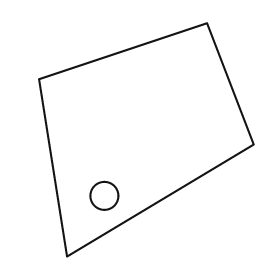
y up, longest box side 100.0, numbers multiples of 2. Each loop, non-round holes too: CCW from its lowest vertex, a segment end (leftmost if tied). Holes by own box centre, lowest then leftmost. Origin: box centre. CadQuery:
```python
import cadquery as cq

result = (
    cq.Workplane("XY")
    .moveTo(-34.0, -50.0)
    .lineTo(46.0, -2.0)
    .lineTo(26.0, 50.0)
    .lineTo(-46.0, 26.0)
    .close()
    .moveTo(-18.0, -24.0)
    .circle(6.0)
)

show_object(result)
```